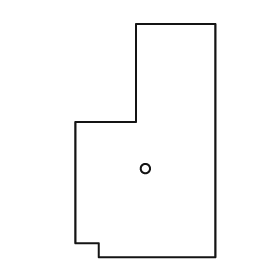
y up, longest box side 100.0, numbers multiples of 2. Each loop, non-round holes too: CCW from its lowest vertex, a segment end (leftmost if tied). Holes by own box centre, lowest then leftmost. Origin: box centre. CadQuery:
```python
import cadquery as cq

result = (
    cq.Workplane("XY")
    .moveTo(-20.0, -50.0)
    .lineTo(30.0, -50.0)
    .lineTo(30.0, 50.0)
    .lineTo(-4.0, 50.0)
    .lineTo(-4.0, 8.0)
    .lineTo(-30.0, 8.0)
    .lineTo(-30.0, -44.0)
    .lineTo(-20.0, -44.0)
    .close()
    .moveTo(0.0, -12.0)
    .circle(2.0)
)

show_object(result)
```